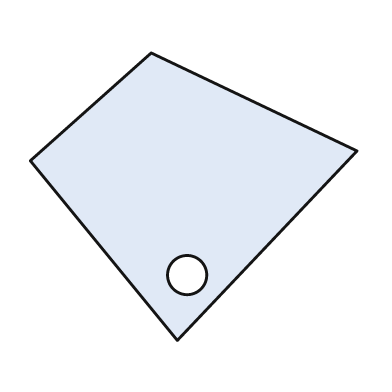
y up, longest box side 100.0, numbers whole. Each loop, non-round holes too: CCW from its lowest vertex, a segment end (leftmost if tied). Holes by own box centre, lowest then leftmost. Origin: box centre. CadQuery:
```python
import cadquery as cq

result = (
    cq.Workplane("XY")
    .moveTo(-5.0, -44.0)
    .lineTo(50.0, 14.0)
    .lineTo(-13.0, 44.0)
    .lineTo(-50.0, 11.0)
    .close()
    .moveTo(-2.0, -24.0)
    .circle(6.0)
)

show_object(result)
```